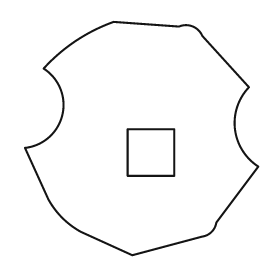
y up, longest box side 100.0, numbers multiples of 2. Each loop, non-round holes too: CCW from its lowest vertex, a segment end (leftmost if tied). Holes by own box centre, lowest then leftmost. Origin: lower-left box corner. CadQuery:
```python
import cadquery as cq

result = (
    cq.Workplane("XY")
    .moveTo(46.0, 0.0)
    .lineTo(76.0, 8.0)
    .threePointArc((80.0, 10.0), (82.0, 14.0))
    .lineTo(100.0, 38.0)
    .threePointArc((90.0, 54.0), (96.0, 72.0))
    .lineTo(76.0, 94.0)
    .threePointArc((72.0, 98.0), (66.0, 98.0))
    .lineTo(38.0, 100.0)
    .threePointArc((22.0, 92.0), (8.0, 80.0))
    .threePointArc((16.0, 60.0), (0.0, 46.0))
    .lineTo(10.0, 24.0)
    .threePointArc((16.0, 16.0), (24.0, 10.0))
    .close()
    .moveTo(44.0, 34.0)
    .lineTo(64.0, 34.0)
    .lineTo(64.0, 54.0)
    .lineTo(44.0, 54.0)
    .close()
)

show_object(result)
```